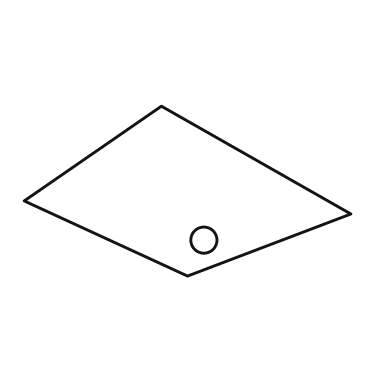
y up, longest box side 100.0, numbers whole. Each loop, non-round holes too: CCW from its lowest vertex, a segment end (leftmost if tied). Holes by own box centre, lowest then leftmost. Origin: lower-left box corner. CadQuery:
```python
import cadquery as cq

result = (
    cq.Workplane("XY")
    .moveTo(50.0, 0.0)
    .lineTo(100.0, 19.0)
    .lineTo(42.0, 52.0)
    .lineTo(0.0, 23.0)
    .close()
    .moveTo(55.0, 11.0)
    .circle(4.0)
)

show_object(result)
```